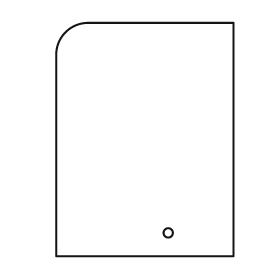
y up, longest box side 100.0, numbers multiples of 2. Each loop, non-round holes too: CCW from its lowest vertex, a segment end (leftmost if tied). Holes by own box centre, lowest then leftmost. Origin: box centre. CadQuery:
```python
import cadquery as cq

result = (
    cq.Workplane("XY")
    .moveTo(-38.0, -50.0)
    .lineTo(38.0, -50.0)
    .lineTo(38.0, 50.0)
    .lineTo(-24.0, 50.0)
    .threePointArc((-34.0, 46.0), (-38.0, 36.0))
    .close()
    .moveTo(10.0, -40.0)
    .circle(2.0)
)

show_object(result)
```